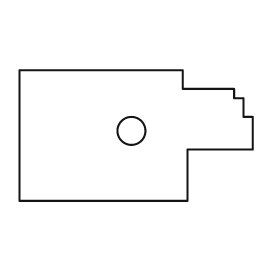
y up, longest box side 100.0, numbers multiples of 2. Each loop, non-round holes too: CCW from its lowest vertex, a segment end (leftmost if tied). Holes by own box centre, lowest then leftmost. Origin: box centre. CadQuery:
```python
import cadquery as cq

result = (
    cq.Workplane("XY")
    .moveTo(-50.0, -28.0)
    .lineTo(22.0, -28.0)
    .lineTo(22.0, -6.0)
    .lineTo(50.0, -6.0)
    .lineTo(50.0, 8.0)
    .lineTo(46.0, 8.0)
    .lineTo(46.0, 16.0)
    .lineTo(42.0, 16.0)
    .lineTo(42.0, 20.0)
    .lineTo(20.0, 20.0)
    .lineTo(20.0, 28.0)
    .lineTo(-50.0, 28.0)
    .close()
    .moveTo(-2.0, 2.0)
    .circle(6.0)
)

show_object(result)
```